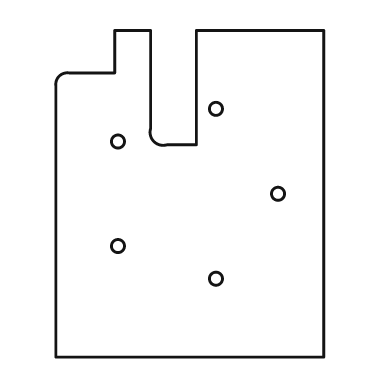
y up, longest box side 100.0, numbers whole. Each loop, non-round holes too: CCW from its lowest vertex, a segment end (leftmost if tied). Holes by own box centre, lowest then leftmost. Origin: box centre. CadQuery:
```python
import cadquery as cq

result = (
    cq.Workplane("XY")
    .moveTo(-41.0, -50.0)
    .lineTo(41.0, -50.0)
    .lineTo(41.0, 50.0)
    .lineTo(2.0, 50.0)
    .lineTo(2.0, 15.0)
    .lineTo(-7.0, 15.0)
    .threePointArc((-11.0, 16.0), (-12.0, 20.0))
    .lineTo(-12.0, 50.0)
    .lineTo(-23.0, 50.0)
    .lineTo(-23.0, 37.0)
    .lineTo(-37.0, 37.0)
    .threePointArc((-40.0, 36.0), (-41.0, 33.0))
    .close()
    .moveTo(8.0, -26.0)
    .circle(2.0)
    .moveTo(-22.0, -16.0)
    .circle(2.0)
    .moveTo(27.0, 0.0)
    .circle(2.0)
    .moveTo(-22.0, 16.0)
    .circle(2.0)
    .moveTo(8.0, 26.0)
    .circle(2.0)
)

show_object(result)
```